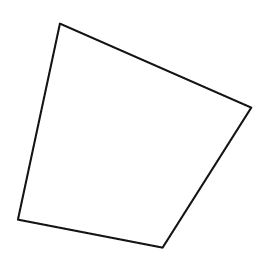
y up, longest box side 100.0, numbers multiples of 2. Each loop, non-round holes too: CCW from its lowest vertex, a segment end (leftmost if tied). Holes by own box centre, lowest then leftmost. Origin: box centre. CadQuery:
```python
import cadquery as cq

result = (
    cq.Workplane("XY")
    .moveTo(12.0, -48.0)
    .lineTo(50.0, 12.0)
    .lineTo(-32.0, 48.0)
    .lineTo(-50.0, -36.0)
    .close()
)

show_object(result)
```